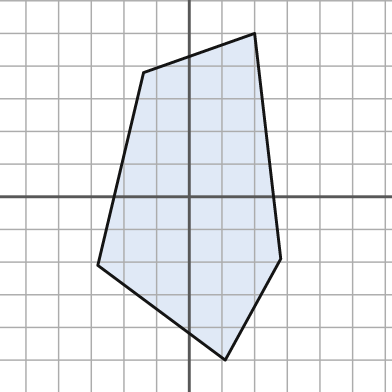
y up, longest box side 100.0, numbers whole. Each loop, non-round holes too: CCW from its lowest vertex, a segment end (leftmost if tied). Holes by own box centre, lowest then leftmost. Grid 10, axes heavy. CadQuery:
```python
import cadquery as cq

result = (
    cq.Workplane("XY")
    .moveTo(11.0, -50.0)
    .lineTo(28.0, -19.0)
    .lineTo(20.0, 50.0)
    .lineTo(-14.0, 38.0)
    .lineTo(-28.0, -21.0)
    .close()
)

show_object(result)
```